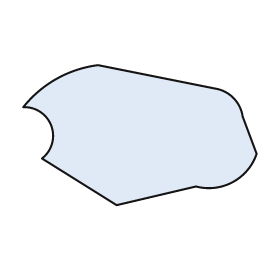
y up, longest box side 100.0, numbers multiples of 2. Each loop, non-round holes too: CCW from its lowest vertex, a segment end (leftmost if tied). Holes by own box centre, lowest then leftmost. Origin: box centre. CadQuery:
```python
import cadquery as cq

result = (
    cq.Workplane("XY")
    .moveTo(-10.0, -30.0)
    .lineTo(24.0, -22.0)
    .threePointArc((40.0, -20.0), (50.0, -8.0))
    .lineTo(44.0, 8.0)
    .threePointArc((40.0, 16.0), (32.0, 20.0))
    .lineTo(-18.0, 30.0)
    .threePointArc((-36.0, 24.0), (-50.0, 12.0))
    .threePointArc((-38.0, 4.0), (-42.0, -10.0))
    .close()
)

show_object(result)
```